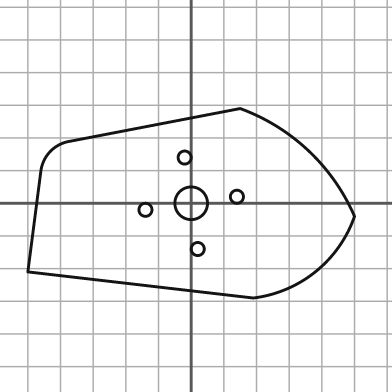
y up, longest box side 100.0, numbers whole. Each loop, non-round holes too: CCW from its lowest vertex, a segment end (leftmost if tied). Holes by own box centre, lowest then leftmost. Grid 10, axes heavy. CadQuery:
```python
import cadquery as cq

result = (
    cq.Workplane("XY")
    .moveTo(19.0, -29.0)
    .threePointArc((38.0, -21.0), (50.0, -4.0))
    .threePointArc((36.0, 16.0), (15.0, 29.0))
    .lineTo(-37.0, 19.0)
    .threePointArc((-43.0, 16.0), (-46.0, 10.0))
    .lineTo(-50.0, -21.0)
    .close()
    .moveTo(2.0, -14.0)
    .circle(2.0)
    .moveTo(-14.0, -2.0)
    .circle(2.0)
    .moveTo(0.0, 0.0)
    .circle(5.0)
    .moveTo(14.0, 2.0)
    .circle(2.0)
    .moveTo(-2.0, 14.0)
    .circle(2.0)
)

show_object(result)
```